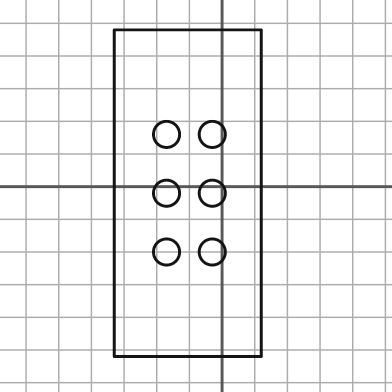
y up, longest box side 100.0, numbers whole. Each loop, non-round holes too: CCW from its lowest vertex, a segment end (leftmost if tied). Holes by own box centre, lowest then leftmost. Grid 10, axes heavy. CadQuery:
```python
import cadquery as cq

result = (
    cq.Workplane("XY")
    .moveTo(-33.0, -52.0)
    .lineTo(12.0, -52.0)
    .lineTo(12.0, 48.0)
    .lineTo(-33.0, 48.0)
    .close()
    .moveTo(-17.0, -20.0)
    .circle(4.0)
    .moveTo(-3.0, -20.0)
    .circle(4.0)
    .moveTo(-17.0, -2.0)
    .circle(4.0)
    .moveTo(-3.0, -2.0)
    .circle(4.0)
    .moveTo(-17.0, 16.0)
    .circle(4.0)
    .moveTo(-3.0, 16.0)
    .circle(4.0)
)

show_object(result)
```